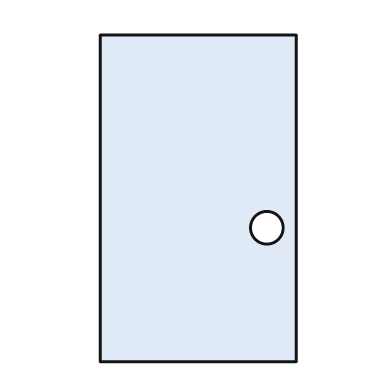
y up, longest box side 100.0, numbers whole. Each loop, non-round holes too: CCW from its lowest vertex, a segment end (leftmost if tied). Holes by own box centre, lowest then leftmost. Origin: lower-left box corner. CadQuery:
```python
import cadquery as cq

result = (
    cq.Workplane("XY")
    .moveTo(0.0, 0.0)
    .lineTo(60.0, 0.0)
    .lineTo(60.0, 100.0)
    .lineTo(0.0, 100.0)
    .close()
    .moveTo(51.0, 41.0)
    .circle(5.0)
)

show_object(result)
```